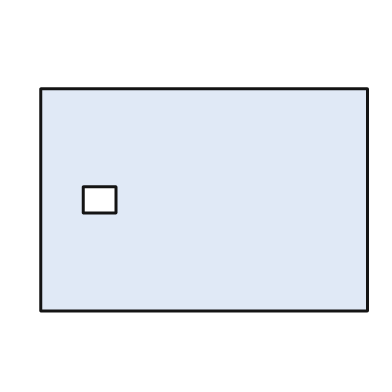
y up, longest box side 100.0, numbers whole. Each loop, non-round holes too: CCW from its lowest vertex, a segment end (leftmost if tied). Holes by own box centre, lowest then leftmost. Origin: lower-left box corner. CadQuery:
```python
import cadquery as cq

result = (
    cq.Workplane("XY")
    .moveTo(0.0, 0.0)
    .lineTo(100.0, 0.0)
    .lineTo(100.0, 68.0)
    .lineTo(0.0, 68.0)
    .close()
    .moveTo(13.0, 30.0)
    .lineTo(23.0, 30.0)
    .lineTo(23.0, 38.0)
    .lineTo(13.0, 38.0)
    .close()
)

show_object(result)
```